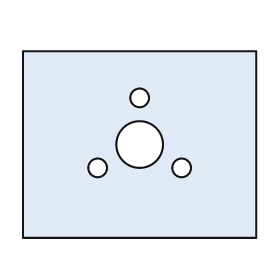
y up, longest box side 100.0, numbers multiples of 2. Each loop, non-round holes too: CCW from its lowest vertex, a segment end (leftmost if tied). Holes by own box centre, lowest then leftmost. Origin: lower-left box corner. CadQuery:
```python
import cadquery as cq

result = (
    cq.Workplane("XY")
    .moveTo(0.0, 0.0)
    .lineTo(100.0, 0.0)
    .lineTo(100.0, 80.0)
    .lineTo(0.0, 80.0)
    .close()
    .moveTo(32.0, 30.0)
    .circle(4.0)
    .moveTo(68.0, 30.0)
    .circle(4.0)
    .moveTo(50.0, 40.0)
    .circle(10.0)
    .moveTo(50.0, 60.0)
    .circle(4.0)
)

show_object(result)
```